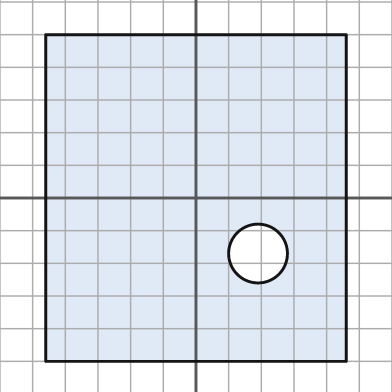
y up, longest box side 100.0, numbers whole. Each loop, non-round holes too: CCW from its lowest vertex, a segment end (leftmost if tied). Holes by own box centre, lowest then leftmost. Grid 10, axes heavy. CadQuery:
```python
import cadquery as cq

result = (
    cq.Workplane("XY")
    .moveTo(-46.0, -50.0)
    .lineTo(46.0, -50.0)
    .lineTo(46.0, 50.0)
    .lineTo(-46.0, 50.0)
    .close()
    .moveTo(19.0, -17.0)
    .circle(9.0)
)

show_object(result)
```